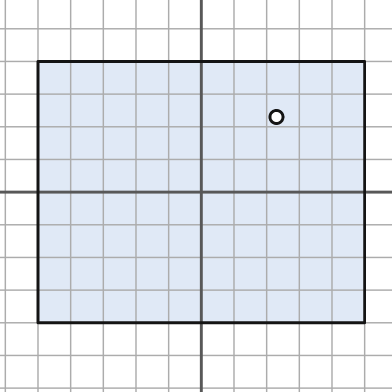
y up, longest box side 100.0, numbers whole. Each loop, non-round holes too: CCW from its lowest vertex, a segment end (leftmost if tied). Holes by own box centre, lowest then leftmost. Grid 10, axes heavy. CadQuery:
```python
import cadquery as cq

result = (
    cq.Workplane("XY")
    .moveTo(-50.0, -40.0)
    .lineTo(50.0, -40.0)
    .lineTo(50.0, 40.0)
    .lineTo(-50.0, 40.0)
    .close()
    .moveTo(23.0, 23.0)
    .circle(2.0)
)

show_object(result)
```